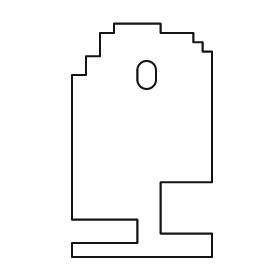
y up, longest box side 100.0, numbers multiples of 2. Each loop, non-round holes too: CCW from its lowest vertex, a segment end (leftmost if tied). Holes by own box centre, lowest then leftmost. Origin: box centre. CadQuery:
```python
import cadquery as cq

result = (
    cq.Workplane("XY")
    .moveTo(-30.0, -50.0)
    .lineTo(30.0, -50.0)
    .lineTo(30.0, -40.0)
    .lineTo(8.0, -40.0)
    .lineTo(8.0, -18.0)
    .lineTo(30.0, -18.0)
    .lineTo(30.0, 38.0)
    .lineTo(26.0, 38.0)
    .lineTo(26.0, 42.0)
    .lineTo(22.0, 42.0)
    .lineTo(22.0, 46.0)
    .lineTo(8.0, 46.0)
    .lineTo(8.0, 50.0)
    .lineTo(-12.0, 50.0)
    .lineTo(-12.0, 46.0)
    .lineTo(-18.0, 46.0)
    .lineTo(-18.0, 36.0)
    .lineTo(-24.0, 36.0)
    .lineTo(-24.0, 28.0)
    .lineTo(-30.0, 28.0)
    .lineTo(-30.0, -34.0)
    .lineTo(-2.0, -34.0)
    .lineTo(-2.0, -44.0)
    .lineTo(-30.0, -44.0)
    .close()
    .moveTo(-2.0, 26.0)
    .threePointArc((2.0, 22.0), (6.0, 26.0))
    .lineTo(6.0, 30.0)
    .threePointArc((2.0, 34.0), (-2.0, 30.0))
    .close()
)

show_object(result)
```